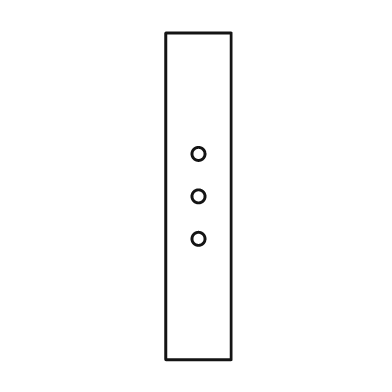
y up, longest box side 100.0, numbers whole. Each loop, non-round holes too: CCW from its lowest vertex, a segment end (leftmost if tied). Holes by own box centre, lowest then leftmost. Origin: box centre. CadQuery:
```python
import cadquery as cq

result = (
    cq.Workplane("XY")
    .moveTo(-10.0, -50.0)
    .lineTo(10.0, -50.0)
    .lineTo(10.0, 50.0)
    .lineTo(-10.0, 50.0)
    .close()
    .moveTo(0.0, -13.0)
    .circle(2.0)
    .moveTo(0.0, 0.0)
    .circle(2.0)
    .moveTo(0.0, 13.0)
    .circle(2.0)
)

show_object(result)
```